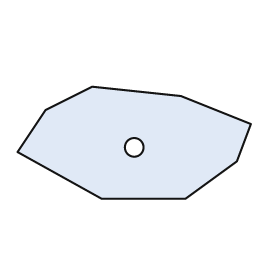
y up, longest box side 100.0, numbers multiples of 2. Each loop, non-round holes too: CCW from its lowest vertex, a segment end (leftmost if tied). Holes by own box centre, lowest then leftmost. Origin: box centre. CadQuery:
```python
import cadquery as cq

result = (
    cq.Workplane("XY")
    .moveTo(-14.0, -24.0)
    .lineTo(22.0, -24.0)
    .lineTo(44.0, -8.0)
    .lineTo(50.0, 8.0)
    .lineTo(20.0, 20.0)
    .lineTo(-18.0, 24.0)
    .lineTo(-38.0, 14.0)
    .lineTo(-50.0, -4.0)
    .close()
    .moveTo(0.0, -2.0)
    .circle(4.0)
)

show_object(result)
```